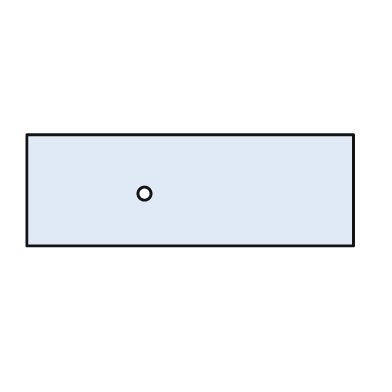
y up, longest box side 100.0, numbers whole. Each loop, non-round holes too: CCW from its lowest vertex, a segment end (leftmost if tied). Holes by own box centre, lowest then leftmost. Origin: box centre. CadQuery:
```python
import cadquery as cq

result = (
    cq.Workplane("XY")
    .moveTo(-50.0, -17.0)
    .lineTo(50.0, -17.0)
    .lineTo(50.0, 17.0)
    .lineTo(-50.0, 17.0)
    .close()
    .moveTo(-14.0, -1.0)
    .circle(2.0)
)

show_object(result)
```